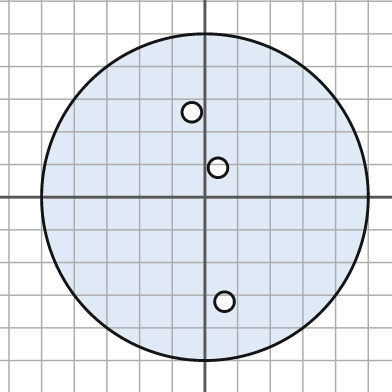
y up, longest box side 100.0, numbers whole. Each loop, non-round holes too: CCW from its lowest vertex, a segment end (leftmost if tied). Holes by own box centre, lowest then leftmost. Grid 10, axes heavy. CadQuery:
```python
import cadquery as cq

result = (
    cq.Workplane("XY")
    .moveTo(0.0, 0.0)
    .circle(50.0)
    .moveTo(6.0, -32.0)
    .circle(3.0)
    .moveTo(4.0, 9.0)
    .circle(3.0)
    .moveTo(-4.0, 26.0)
    .circle(3.0)
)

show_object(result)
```